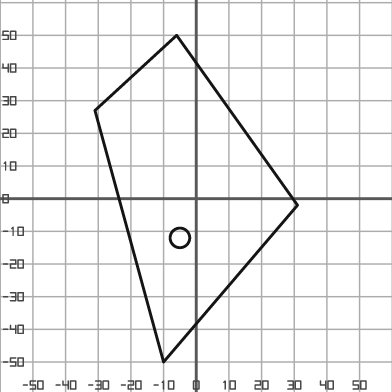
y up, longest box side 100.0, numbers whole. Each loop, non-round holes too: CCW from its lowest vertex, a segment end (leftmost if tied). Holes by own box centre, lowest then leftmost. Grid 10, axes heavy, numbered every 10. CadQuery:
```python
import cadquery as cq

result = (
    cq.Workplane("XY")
    .moveTo(-10.0, -50.0)
    .lineTo(31.0, -2.0)
    .lineTo(-6.0, 50.0)
    .lineTo(-31.0, 27.0)
    .close()
    .moveTo(-5.0, -12.0)
    .circle(3.0)
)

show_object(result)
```